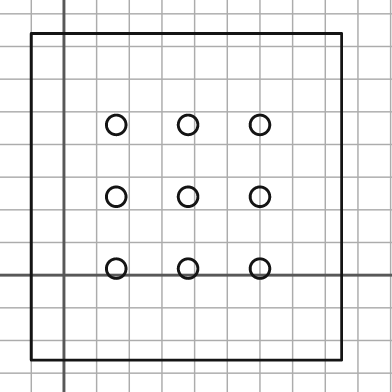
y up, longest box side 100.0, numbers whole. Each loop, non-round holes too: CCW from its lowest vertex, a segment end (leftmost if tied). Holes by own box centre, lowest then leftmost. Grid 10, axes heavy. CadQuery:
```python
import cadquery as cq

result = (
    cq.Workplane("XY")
    .moveTo(-10.0, -26.0)
    .lineTo(85.0, -26.0)
    .lineTo(85.0, 74.0)
    .lineTo(-10.0, 74.0)
    .close()
    .moveTo(16.0, 2.0)
    .circle(3.0)
    .moveTo(38.0, 2.0)
    .circle(3.0)
    .moveTo(60.0, 2.0)
    .circle(3.0)
    .moveTo(16.0, 24.0)
    .circle(3.0)
    .moveTo(38.0, 24.0)
    .circle(3.0)
    .moveTo(60.0, 24.0)
    .circle(3.0)
    .moveTo(16.0, 46.0)
    .circle(3.0)
    .moveTo(38.0, 46.0)
    .circle(3.0)
    .moveTo(60.0, 46.0)
    .circle(3.0)
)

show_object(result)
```